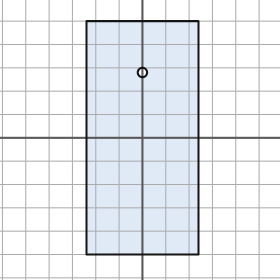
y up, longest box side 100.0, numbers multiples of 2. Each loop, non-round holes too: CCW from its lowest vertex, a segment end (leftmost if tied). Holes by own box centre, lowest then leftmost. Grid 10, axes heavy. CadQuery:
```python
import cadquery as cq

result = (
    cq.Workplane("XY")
    .moveTo(-24.0, -50.0)
    .lineTo(24.0, -50.0)
    .lineTo(24.0, 50.0)
    .lineTo(-24.0, 50.0)
    .close()
    .moveTo(0.0, 28.0)
    .circle(2.0)
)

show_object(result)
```